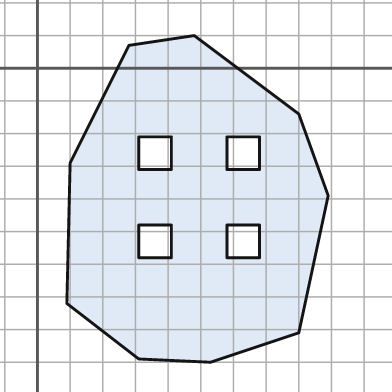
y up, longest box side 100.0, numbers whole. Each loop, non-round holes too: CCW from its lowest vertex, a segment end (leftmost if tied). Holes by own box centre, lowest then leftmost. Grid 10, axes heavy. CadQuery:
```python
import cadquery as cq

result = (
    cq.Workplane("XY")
    .moveTo(53.0, -90.0)
    .lineTo(80.0, -81.0)
    .lineTo(89.0, -39.0)
    .lineTo(80.0, -14.0)
    .lineTo(48.0, 10.0)
    .lineTo(28.0, 7.0)
    .lineTo(10.0, -29.0)
    .lineTo(9.0, -72.0)
    .lineTo(31.0, -89.0)
    .close()
    .moveTo(31.0, -58.0)
    .lineTo(41.0, -58.0)
    .lineTo(41.0, -48.0)
    .lineTo(31.0, -48.0)
    .close()
    .moveTo(58.0, -58.0)
    .lineTo(68.0, -58.0)
    .lineTo(68.0, -48.0)
    .lineTo(58.0, -48.0)
    .close()
    .moveTo(31.0, -31.0)
    .lineTo(41.0, -31.0)
    .lineTo(41.0, -21.0)
    .lineTo(31.0, -21.0)
    .close()
    .moveTo(58.0, -31.0)
    .lineTo(68.0, -31.0)
    .lineTo(68.0, -21.0)
    .lineTo(58.0, -21.0)
    .close()
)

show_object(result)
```